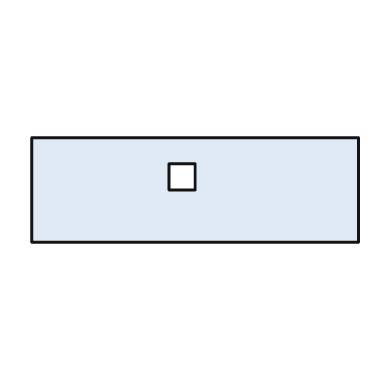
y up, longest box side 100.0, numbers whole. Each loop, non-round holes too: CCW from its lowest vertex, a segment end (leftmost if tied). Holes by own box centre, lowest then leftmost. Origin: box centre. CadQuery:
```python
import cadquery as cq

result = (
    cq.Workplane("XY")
    .moveTo(-50.0, -16.0)
    .lineTo(50.0, -16.0)
    .lineTo(50.0, 16.0)
    .lineTo(-50.0, 16.0)
    .close()
    .moveTo(-8.0, 0.0)
    .lineTo(0.0, 0.0)
    .lineTo(0.0, 8.0)
    .lineTo(-8.0, 8.0)
    .close()
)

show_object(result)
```